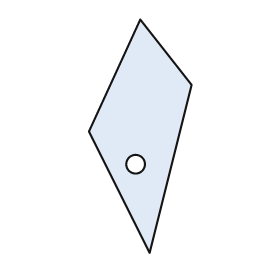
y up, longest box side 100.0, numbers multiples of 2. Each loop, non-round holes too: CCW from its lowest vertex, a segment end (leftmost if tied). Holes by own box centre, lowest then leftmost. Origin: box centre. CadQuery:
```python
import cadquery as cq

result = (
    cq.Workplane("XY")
    .moveTo(4.0, -50.0)
    .lineTo(22.0, 22.0)
    .lineTo(0.0, 50.0)
    .lineTo(-22.0, 2.0)
    .close()
    .moveTo(-2.0, -12.0)
    .circle(4.0)
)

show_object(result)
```